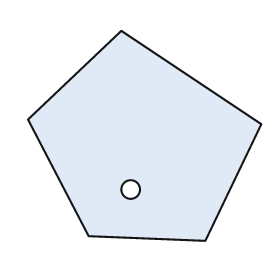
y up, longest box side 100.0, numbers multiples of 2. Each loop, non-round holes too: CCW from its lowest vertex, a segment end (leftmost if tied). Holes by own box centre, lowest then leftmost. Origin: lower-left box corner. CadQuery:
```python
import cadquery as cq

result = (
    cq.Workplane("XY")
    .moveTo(76.0, 0.0)
    .lineTo(100.0, 50.0)
    .lineTo(40.0, 90.0)
    .lineTo(0.0, 52.0)
    .lineTo(26.0, 2.0)
    .close()
    .moveTo(44.0, 22.0)
    .circle(4.0)
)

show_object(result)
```